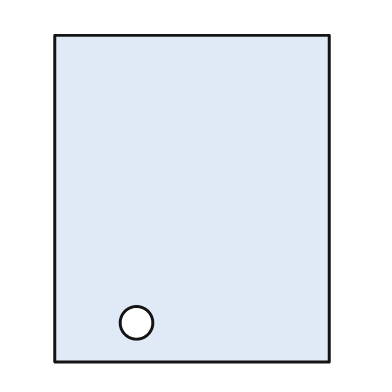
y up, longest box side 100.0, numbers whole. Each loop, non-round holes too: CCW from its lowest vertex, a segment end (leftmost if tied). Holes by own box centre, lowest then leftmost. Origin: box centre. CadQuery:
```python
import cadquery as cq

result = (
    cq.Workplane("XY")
    .moveTo(-42.0, -50.0)
    .lineTo(42.0, -50.0)
    .lineTo(42.0, 50.0)
    .lineTo(-42.0, 50.0)
    .close()
    .moveTo(-17.0, -38.0)
    .circle(5.0)
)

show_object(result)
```